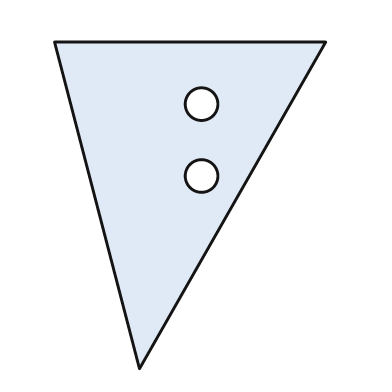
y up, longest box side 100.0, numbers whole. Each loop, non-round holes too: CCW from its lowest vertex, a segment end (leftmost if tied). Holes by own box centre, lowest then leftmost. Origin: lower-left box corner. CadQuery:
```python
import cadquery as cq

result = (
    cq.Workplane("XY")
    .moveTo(26.0, 0.0)
    .lineTo(83.0, 100.0)
    .lineTo(0.0, 100.0)
    .close()
    .moveTo(45.0, 59.0)
    .circle(5.0)
    .moveTo(45.0, 81.0)
    .circle(5.0)
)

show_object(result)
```